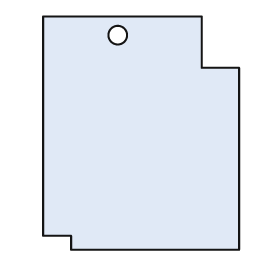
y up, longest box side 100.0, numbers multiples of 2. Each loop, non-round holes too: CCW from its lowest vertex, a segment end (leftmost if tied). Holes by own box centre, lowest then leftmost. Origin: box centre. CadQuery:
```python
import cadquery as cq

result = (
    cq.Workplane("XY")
    .moveTo(-30.0, -50.0)
    .lineTo(42.0, -50.0)
    .lineTo(42.0, 28.0)
    .lineTo(26.0, 28.0)
    .lineTo(26.0, 50.0)
    .lineTo(-42.0, 50.0)
    .lineTo(-42.0, -44.0)
    .lineTo(-30.0, -44.0)
    .close()
    .moveTo(-10.0, 42.0)
    .circle(4.0)
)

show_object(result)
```